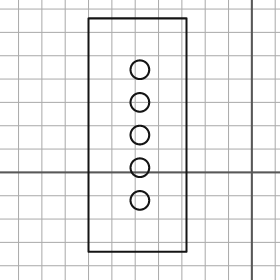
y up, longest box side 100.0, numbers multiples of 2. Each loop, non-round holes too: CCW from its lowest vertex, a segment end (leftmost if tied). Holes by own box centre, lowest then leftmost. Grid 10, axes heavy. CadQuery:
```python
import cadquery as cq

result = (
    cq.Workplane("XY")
    .moveTo(-70.0, -34.0)
    .lineTo(-28.0, -34.0)
    .lineTo(-28.0, 66.0)
    .lineTo(-70.0, 66.0)
    .close()
    .moveTo(-48.0, -12.0)
    .circle(4.0)
    .moveTo(-48.0, 2.0)
    .circle(4.0)
    .moveTo(-48.0, 16.0)
    .circle(4.0)
    .moveTo(-48.0, 30.0)
    .circle(4.0)
    .moveTo(-48.0, 44.0)
    .circle(4.0)
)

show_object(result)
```